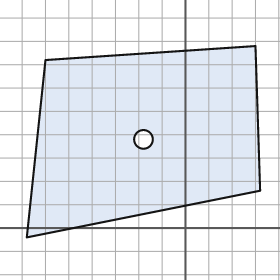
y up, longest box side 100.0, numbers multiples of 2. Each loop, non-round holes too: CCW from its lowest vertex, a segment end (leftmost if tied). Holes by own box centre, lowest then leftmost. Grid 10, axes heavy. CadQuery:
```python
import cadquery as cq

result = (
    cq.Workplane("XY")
    .moveTo(-68.0, -4.0)
    .lineTo(32.0, 16.0)
    .lineTo(30.0, 78.0)
    .lineTo(-60.0, 72.0)
    .close()
    .moveTo(-18.0, 38.0)
    .circle(4.0)
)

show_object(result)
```